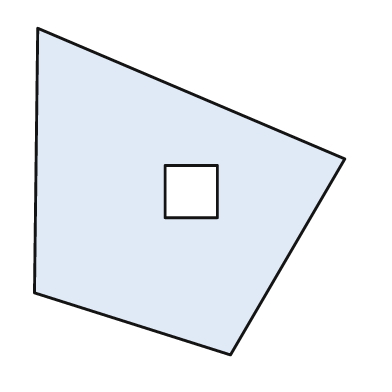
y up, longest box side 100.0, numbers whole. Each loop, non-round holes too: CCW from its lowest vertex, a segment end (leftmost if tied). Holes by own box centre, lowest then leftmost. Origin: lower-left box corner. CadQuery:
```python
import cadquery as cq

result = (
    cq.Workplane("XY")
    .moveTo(60.0, 0.0)
    .lineTo(95.0, 60.0)
    .lineTo(1.0, 100.0)
    .lineTo(0.0, 19.0)
    .close()
    .moveTo(40.0, 42.0)
    .lineTo(56.0, 42.0)
    .lineTo(56.0, 58.0)
    .lineTo(40.0, 58.0)
    .close()
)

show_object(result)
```